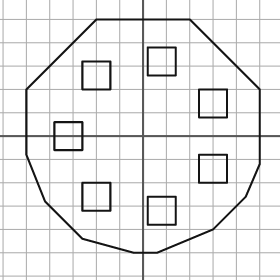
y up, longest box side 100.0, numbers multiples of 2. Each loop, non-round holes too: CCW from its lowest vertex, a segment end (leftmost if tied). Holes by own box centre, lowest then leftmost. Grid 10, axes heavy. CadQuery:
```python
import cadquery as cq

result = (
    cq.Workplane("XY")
    .moveTo(-4.0, -50.0)
    .lineTo(6.0, -50.0)
    .lineTo(30.0, -40.0)
    .lineTo(44.0, -26.0)
    .lineTo(50.0, -12.0)
    .lineTo(50.0, 20.0)
    .lineTo(20.0, 50.0)
    .lineTo(-20.0, 50.0)
    .lineTo(-50.0, 20.0)
    .lineTo(-50.0, -8.0)
    .lineTo(-42.0, -28.0)
    .lineTo(-26.0, -44.0)
    .close()
    .moveTo(2.0, -38.0)
    .lineTo(14.0, -38.0)
    .lineTo(14.0, -26.0)
    .lineTo(2.0, -26.0)
    .close()
    .moveTo(-26.0, -32.0)
    .lineTo(-14.0, -32.0)
    .lineTo(-14.0, -20.0)
    .lineTo(-26.0, -20.0)
    .close()
    .moveTo(24.0, -20.0)
    .lineTo(36.0, -20.0)
    .lineTo(36.0, -8.0)
    .lineTo(24.0, -8.0)
    .close()
    .moveTo(-38.0, -6.0)
    .lineTo(-26.0, -6.0)
    .lineTo(-26.0, 6.0)
    .lineTo(-38.0, 6.0)
    .close()
    .moveTo(24.0, 8.0)
    .lineTo(36.0, 8.0)
    .lineTo(36.0, 20.0)
    .lineTo(24.0, 20.0)
    .close()
    .moveTo(-26.0, 20.0)
    .lineTo(-14.0, 20.0)
    .lineTo(-14.0, 32.0)
    .lineTo(-26.0, 32.0)
    .close()
    .moveTo(2.0, 26.0)
    .lineTo(14.0, 26.0)
    .lineTo(14.0, 38.0)
    .lineTo(2.0, 38.0)
    .close()
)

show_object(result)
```